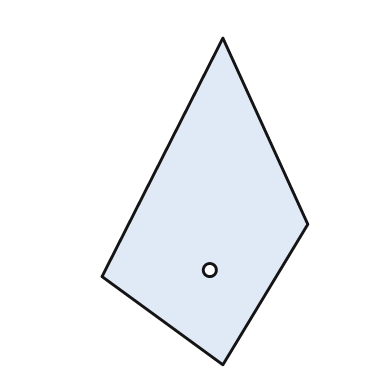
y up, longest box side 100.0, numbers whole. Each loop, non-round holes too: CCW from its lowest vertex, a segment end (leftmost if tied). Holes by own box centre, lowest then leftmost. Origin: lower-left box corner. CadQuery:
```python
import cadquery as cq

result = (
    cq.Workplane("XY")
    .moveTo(37.0, 0.0)
    .lineTo(63.0, 43.0)
    .lineTo(37.0, 100.0)
    .lineTo(0.0, 27.0)
    .close()
    .moveTo(33.0, 29.0)
    .circle(2.0)
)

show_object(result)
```